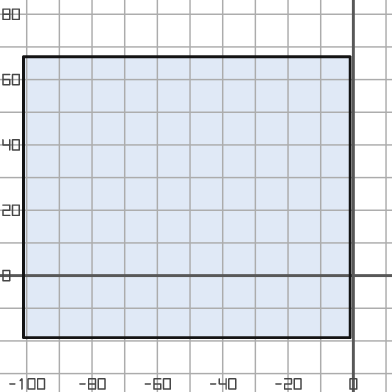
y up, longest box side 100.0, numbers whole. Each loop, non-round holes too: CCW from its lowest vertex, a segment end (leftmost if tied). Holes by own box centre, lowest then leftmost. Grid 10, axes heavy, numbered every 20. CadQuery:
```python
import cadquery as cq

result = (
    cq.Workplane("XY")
    .moveTo(-101.0, -19.0)
    .lineTo(-1.0, -19.0)
    .lineTo(-1.0, 67.0)
    .lineTo(-101.0, 67.0)
    .close()
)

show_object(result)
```